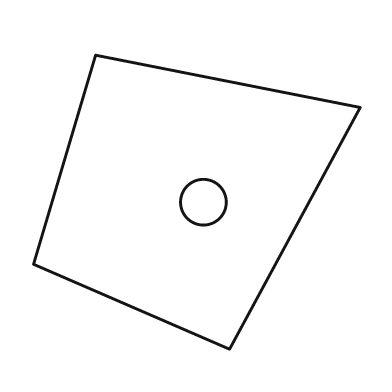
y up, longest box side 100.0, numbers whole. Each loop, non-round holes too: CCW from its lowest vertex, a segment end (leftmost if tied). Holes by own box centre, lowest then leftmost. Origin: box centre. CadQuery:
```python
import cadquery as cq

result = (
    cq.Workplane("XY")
    .moveTo(10.0, -45.0)
    .lineTo(50.0, 29.0)
    .lineTo(-31.0, 45.0)
    .lineTo(-50.0, -19.0)
    .close()
    .moveTo(2.0, 0.0)
    .circle(7.0)
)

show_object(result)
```